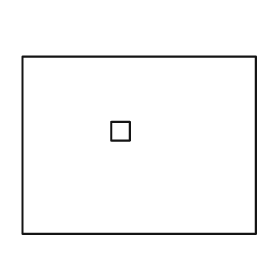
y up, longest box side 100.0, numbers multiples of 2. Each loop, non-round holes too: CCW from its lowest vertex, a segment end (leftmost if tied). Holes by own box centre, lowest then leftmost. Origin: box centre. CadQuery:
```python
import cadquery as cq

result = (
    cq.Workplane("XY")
    .moveTo(-50.0, -38.0)
    .lineTo(50.0, -38.0)
    .lineTo(50.0, 38.0)
    .lineTo(-50.0, 38.0)
    .close()
    .moveTo(-12.0, 2.0)
    .lineTo(-4.0, 2.0)
    .lineTo(-4.0, 10.0)
    .lineTo(-12.0, 10.0)
    .close()
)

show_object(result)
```